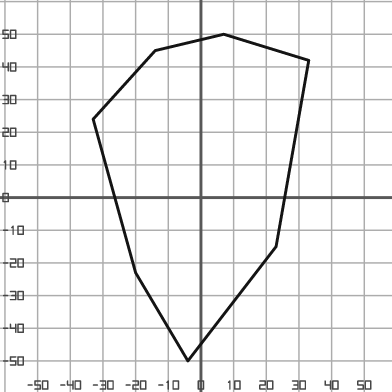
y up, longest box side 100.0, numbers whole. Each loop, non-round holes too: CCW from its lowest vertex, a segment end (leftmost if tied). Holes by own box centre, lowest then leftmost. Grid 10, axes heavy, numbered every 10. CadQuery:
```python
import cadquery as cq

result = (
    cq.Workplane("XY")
    .moveTo(-4.0, -50.0)
    .lineTo(23.0, -15.0)
    .lineTo(33.0, 42.0)
    .lineTo(7.0, 50.0)
    .lineTo(-14.0, 45.0)
    .lineTo(-33.0, 24.0)
    .lineTo(-20.0, -23.0)
    .close()
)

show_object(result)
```